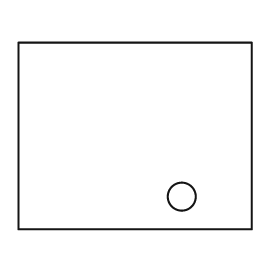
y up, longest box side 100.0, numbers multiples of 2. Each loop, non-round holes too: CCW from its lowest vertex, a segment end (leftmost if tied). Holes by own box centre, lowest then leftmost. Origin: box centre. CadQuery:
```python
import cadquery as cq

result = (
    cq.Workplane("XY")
    .moveTo(-50.0, -40.0)
    .lineTo(50.0, -40.0)
    .lineTo(50.0, 40.0)
    .lineTo(-50.0, 40.0)
    .close()
    .moveTo(20.0, -26.0)
    .circle(6.0)
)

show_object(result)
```